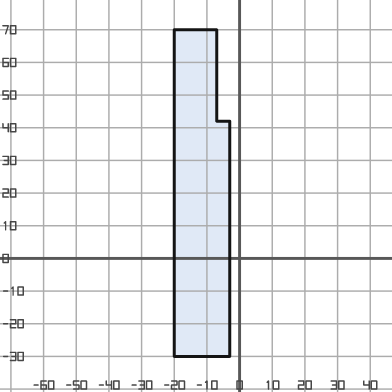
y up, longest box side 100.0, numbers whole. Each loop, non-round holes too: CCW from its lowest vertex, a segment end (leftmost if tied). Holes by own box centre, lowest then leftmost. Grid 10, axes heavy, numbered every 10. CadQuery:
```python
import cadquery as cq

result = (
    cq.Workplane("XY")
    .moveTo(-20.0, -30.0)
    .lineTo(-3.0, -30.0)
    .lineTo(-3.0, 42.0)
    .lineTo(-7.0, 42.0)
    .lineTo(-7.0, 70.0)
    .lineTo(-20.0, 70.0)
    .close()
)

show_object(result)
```